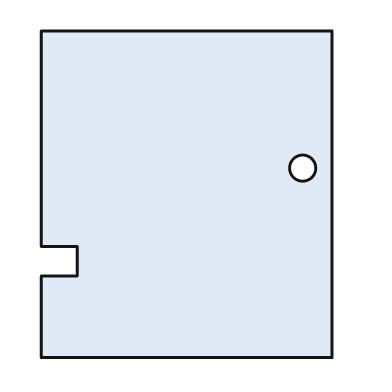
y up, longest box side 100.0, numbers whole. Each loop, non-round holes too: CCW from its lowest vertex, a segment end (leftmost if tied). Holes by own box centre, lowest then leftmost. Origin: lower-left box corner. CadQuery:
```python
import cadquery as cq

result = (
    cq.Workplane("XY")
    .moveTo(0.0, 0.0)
    .lineTo(89.0, 0.0)
    .lineTo(89.0, 100.0)
    .lineTo(0.0, 100.0)
    .lineTo(0.0, 34.0)
    .lineTo(11.0, 34.0)
    .lineTo(11.0, 25.0)
    .lineTo(0.0, 25.0)
    .close()
    .moveTo(80.0, 58.0)
    .circle(4.0)
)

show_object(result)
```